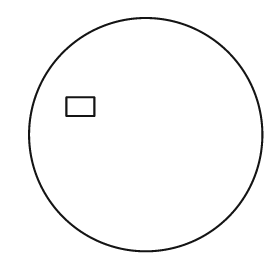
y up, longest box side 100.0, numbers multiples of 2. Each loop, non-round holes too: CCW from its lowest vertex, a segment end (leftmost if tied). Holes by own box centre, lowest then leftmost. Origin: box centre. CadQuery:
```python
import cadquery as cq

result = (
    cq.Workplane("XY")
    .moveTo(0.0, 0.0)
    .circle(50.0)
    .moveTo(-34.0, 8.0)
    .lineTo(-22.0, 8.0)
    .lineTo(-22.0, 16.0)
    .lineTo(-34.0, 16.0)
    .close()
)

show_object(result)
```